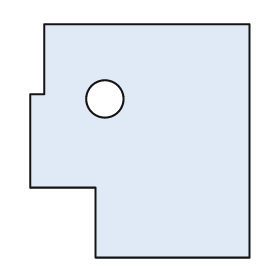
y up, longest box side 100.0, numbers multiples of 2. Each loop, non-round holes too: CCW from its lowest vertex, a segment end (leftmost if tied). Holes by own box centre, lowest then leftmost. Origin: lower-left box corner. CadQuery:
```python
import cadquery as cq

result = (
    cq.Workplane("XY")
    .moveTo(28.0, 0.0)
    .lineTo(94.0, 0.0)
    .lineTo(94.0, 100.0)
    .lineTo(6.0, 100.0)
    .lineTo(6.0, 70.0)
    .lineTo(0.0, 70.0)
    .lineTo(0.0, 30.0)
    .lineTo(28.0, 30.0)
    .close()
    .moveTo(32.0, 68.0)
    .circle(8.0)
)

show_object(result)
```